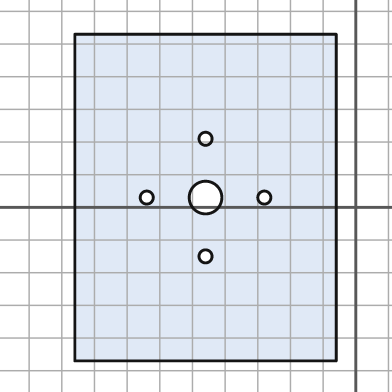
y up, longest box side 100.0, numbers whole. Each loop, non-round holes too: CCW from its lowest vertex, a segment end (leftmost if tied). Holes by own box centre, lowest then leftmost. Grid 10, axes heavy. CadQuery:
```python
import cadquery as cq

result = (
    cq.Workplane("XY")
    .moveTo(-86.0, -47.0)
    .lineTo(-6.0, -47.0)
    .lineTo(-6.0, 53.0)
    .lineTo(-86.0, 53.0)
    .close()
    .moveTo(-46.0, -15.0)
    .circle(2.0)
    .moveTo(-64.0, 3.0)
    .circle(2.0)
    .moveTo(-46.0, 3.0)
    .circle(5.0)
    .moveTo(-28.0, 3.0)
    .circle(2.0)
    .moveTo(-46.0, 21.0)
    .circle(2.0)
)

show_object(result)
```